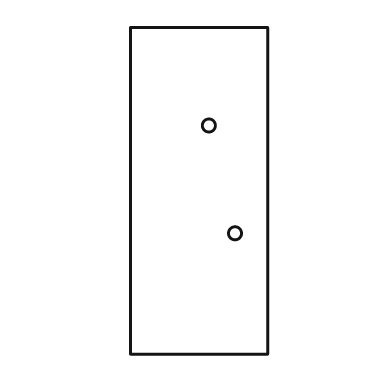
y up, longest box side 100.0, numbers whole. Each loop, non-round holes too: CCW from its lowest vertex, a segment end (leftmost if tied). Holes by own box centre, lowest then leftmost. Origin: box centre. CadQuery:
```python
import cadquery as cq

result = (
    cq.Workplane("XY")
    .moveTo(-21.0, -50.0)
    .lineTo(21.0, -50.0)
    .lineTo(21.0, 50.0)
    .lineTo(-21.0, 50.0)
    .close()
    .moveTo(11.0, -13.0)
    .circle(2.0)
    .moveTo(3.0, 20.0)
    .circle(2.0)
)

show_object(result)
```